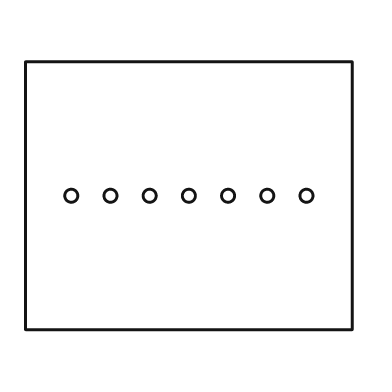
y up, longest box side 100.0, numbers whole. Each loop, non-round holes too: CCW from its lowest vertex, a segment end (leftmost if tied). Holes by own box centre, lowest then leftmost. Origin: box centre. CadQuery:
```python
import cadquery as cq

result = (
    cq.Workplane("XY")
    .moveTo(-50.0, -41.0)
    .lineTo(50.0, -41.0)
    .lineTo(50.0, 41.0)
    .lineTo(-50.0, 41.0)
    .close()
    .moveTo(-36.0, 0.0)
    .circle(2.0)
    .moveTo(-24.0, 0.0)
    .circle(2.0)
    .moveTo(-12.0, 0.0)
    .circle(2.0)
    .moveTo(0.0, 0.0)
    .circle(2.0)
    .moveTo(12.0, 0.0)
    .circle(2.0)
    .moveTo(24.0, 0.0)
    .circle(2.0)
    .moveTo(36.0, 0.0)
    .circle(2.0)
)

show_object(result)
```